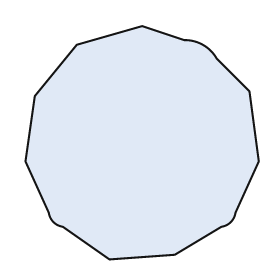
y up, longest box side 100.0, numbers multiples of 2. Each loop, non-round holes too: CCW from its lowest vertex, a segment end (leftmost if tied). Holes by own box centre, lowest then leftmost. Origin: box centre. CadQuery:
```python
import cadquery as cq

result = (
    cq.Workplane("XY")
    .moveTo(-14.0, -50.0)
    .lineTo(14.0, -48.0)
    .lineTo(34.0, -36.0)
    .threePointArc((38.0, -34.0), (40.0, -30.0))
    .lineTo(50.0, -8.0)
    .lineTo(46.0, 22.0)
    .lineTo(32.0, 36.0)
    .threePointArc((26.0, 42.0), (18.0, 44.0))
    .lineTo(0.0, 50.0)
    .lineTo(-28.0, 42.0)
    .lineTo(-46.0, 20.0)
    .lineTo(-50.0, -8.0)
    .lineTo(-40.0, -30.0)
    .threePointArc((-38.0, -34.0), (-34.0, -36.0))
    .close()
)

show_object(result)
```